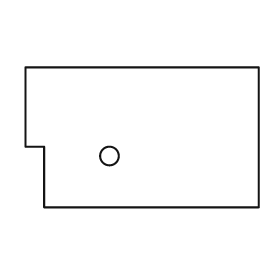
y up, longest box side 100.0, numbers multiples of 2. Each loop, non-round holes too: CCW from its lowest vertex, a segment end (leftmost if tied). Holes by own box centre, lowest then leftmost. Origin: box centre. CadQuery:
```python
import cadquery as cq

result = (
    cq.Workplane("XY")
    .moveTo(-42.0, -30.0)
    .lineTo(50.0, -30.0)
    .lineTo(50.0, 30.0)
    .lineTo(-50.0, 30.0)
    .lineTo(-50.0, -4.0)
    .lineTo(-42.0, -4.0)
    .close()
    .moveTo(-14.0, -8.0)
    .circle(4.0)
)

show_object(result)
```